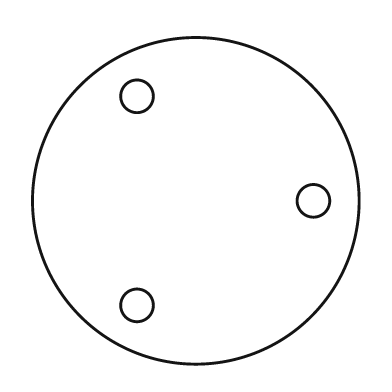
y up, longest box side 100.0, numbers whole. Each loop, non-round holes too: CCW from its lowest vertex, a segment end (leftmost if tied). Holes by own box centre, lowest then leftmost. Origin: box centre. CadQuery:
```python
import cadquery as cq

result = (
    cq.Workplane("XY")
    .moveTo(0.0, 0.0)
    .circle(50.0)
    .moveTo(-18.0, -32.0)
    .circle(5.0)
    .moveTo(36.0, 0.0)
    .circle(5.0)
    .moveTo(-18.0, 32.0)
    .circle(5.0)
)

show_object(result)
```